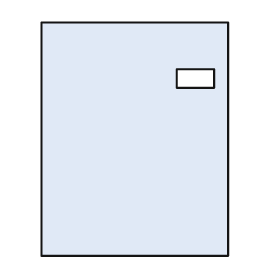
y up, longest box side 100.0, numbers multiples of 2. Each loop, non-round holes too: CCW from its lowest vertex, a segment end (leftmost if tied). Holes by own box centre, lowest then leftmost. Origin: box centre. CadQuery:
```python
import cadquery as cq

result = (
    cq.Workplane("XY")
    .moveTo(-40.0, -50.0)
    .lineTo(40.0, -50.0)
    .lineTo(40.0, 50.0)
    .lineTo(-40.0, 50.0)
    .close()
    .moveTo(18.0, 22.0)
    .lineTo(34.0, 22.0)
    .lineTo(34.0, 30.0)
    .lineTo(18.0, 30.0)
    .close()
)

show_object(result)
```